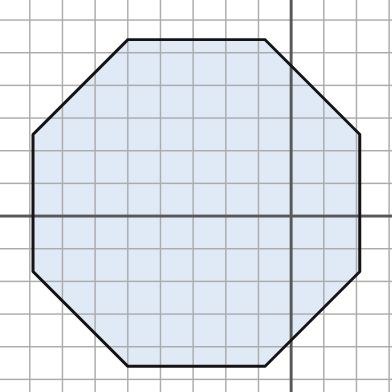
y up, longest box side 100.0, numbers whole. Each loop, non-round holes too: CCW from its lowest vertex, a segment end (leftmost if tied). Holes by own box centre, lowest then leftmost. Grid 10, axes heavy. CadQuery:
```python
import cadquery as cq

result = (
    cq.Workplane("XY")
    .moveTo(-50.0, -46.0)
    .lineTo(-8.0, -46.0)
    .lineTo(21.0, -17.0)
    .lineTo(21.0, 25.0)
    .lineTo(-8.0, 54.0)
    .lineTo(-50.0, 54.0)
    .lineTo(-79.0, 25.0)
    .lineTo(-79.0, -17.0)
    .close()
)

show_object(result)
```